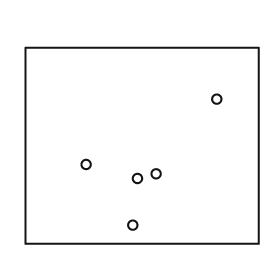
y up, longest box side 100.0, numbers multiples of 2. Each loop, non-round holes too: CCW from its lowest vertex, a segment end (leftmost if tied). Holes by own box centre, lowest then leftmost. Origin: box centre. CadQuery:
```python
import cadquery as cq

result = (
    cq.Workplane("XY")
    .moveTo(-50.0, -42.0)
    .lineTo(50.0, -42.0)
    .lineTo(50.0, 42.0)
    .lineTo(-50.0, 42.0)
    .close()
    .moveTo(-4.0, -34.0)
    .circle(2.0)
    .moveTo(-2.0, -14.0)
    .circle(2.0)
    .moveTo(6.0, -12.0)
    .circle(2.0)
    .moveTo(-24.0, -8.0)
    .circle(2.0)
    .moveTo(32.0, 20.0)
    .circle(2.0)
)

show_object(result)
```